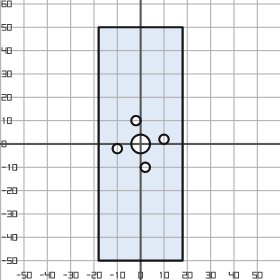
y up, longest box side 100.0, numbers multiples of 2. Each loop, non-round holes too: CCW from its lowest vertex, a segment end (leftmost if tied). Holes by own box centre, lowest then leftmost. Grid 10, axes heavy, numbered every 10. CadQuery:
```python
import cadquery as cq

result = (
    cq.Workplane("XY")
    .moveTo(-18.0, -50.0)
    .lineTo(18.0, -50.0)
    .lineTo(18.0, 50.0)
    .lineTo(-18.0, 50.0)
    .close()
    .moveTo(2.0, -10.0)
    .circle(2.0)
    .moveTo(-10.0, -2.0)
    .circle(2.0)
    .moveTo(0.0, 0.0)
    .circle(4.0)
    .moveTo(10.0, 2.0)
    .circle(2.0)
    .moveTo(-2.0, 10.0)
    .circle(2.0)
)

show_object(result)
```